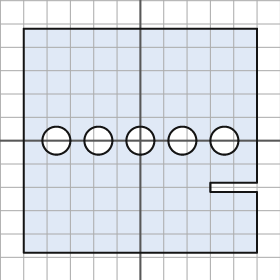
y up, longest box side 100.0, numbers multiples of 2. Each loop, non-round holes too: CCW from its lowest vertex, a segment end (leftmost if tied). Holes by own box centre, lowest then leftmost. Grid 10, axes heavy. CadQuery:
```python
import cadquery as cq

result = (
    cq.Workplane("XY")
    .moveTo(-50.0, -48.0)
    .lineTo(50.0, -48.0)
    .lineTo(50.0, -22.0)
    .lineTo(30.0, -22.0)
    .lineTo(30.0, -18.0)
    .lineTo(50.0, -18.0)
    .lineTo(50.0, 48.0)
    .lineTo(-50.0, 48.0)
    .close()
    .moveTo(-36.0, 0.0)
    .circle(6.0)
    .moveTo(-18.0, 0.0)
    .circle(6.0)
    .moveTo(0.0, 0.0)
    .circle(6.0)
    .moveTo(18.0, 0.0)
    .circle(6.0)
    .moveTo(36.0, 0.0)
    .circle(6.0)
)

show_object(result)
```